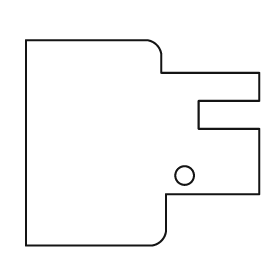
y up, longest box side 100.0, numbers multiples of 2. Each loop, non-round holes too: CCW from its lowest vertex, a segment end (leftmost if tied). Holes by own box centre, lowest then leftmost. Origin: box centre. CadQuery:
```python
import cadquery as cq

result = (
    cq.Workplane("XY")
    .moveTo(-50.0, -44.0)
    .lineTo(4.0, -44.0)
    .threePointArc((8.0, -42.0), (10.0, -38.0))
    .lineTo(10.0, -22.0)
    .lineTo(50.0, -22.0)
    .lineTo(50.0, 6.0)
    .lineTo(24.0, 6.0)
    .lineTo(24.0, 18.0)
    .lineTo(50.0, 18.0)
    .lineTo(50.0, 30.0)
    .lineTo(8.0, 30.0)
    .lineTo(8.0, 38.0)
    .threePointArc((6.0, 42.0), (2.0, 44.0))
    .lineTo(-50.0, 44.0)
    .close()
    .moveTo(18.0, -14.0)
    .circle(4.0)
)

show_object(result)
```